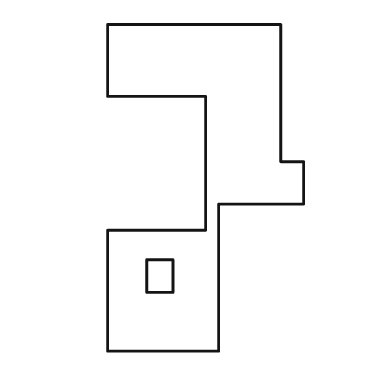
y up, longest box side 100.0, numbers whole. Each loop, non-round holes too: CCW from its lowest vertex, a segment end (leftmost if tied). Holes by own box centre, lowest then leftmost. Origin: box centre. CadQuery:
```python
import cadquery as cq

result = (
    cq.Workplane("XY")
    .moveTo(-30.0, -50.0)
    .lineTo(4.0, -50.0)
    .lineTo(4.0, -5.0)
    .lineTo(30.0, -5.0)
    .lineTo(30.0, 8.0)
    .lineTo(23.0, 8.0)
    .lineTo(23.0, 50.0)
    .lineTo(-30.0, 50.0)
    .lineTo(-30.0, 28.0)
    .lineTo(0.0, 28.0)
    .lineTo(0.0, -13.0)
    .lineTo(-30.0, -13.0)
    .close()
    .moveTo(-18.0, -32.0)
    .lineTo(-10.0, -32.0)
    .lineTo(-10.0, -22.0)
    .lineTo(-18.0, -22.0)
    .close()
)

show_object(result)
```